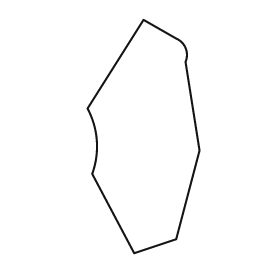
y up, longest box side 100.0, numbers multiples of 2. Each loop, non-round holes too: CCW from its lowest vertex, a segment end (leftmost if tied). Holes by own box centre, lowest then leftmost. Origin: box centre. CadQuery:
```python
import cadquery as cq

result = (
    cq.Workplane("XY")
    .moveTo(-4.0, -50.0)
    .lineTo(14.0, -44.0)
    .lineTo(24.0, -6.0)
    .lineTo(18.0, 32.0)
    .threePointArc((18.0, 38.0), (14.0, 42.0))
    .lineTo(0.0, 50.0)
    .lineTo(-24.0, 12.0)
    .threePointArc((-20.0, -2.0), (-22.0, -16.0))
    .close()
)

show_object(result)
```